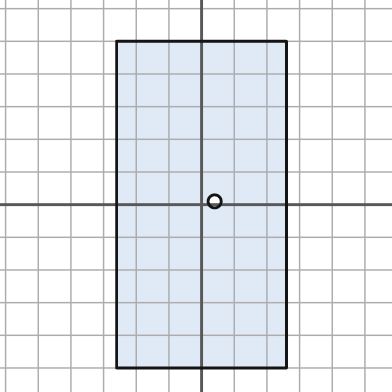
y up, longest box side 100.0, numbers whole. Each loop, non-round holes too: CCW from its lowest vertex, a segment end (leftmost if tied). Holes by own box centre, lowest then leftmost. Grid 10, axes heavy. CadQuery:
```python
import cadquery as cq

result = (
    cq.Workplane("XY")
    .moveTo(-26.0, -50.0)
    .lineTo(26.0, -50.0)
    .lineTo(26.0, 50.0)
    .lineTo(-26.0, 50.0)
    .close()
    .moveTo(4.0, 1.0)
    .circle(2.0)
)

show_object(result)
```